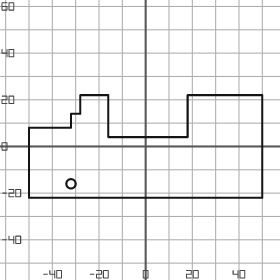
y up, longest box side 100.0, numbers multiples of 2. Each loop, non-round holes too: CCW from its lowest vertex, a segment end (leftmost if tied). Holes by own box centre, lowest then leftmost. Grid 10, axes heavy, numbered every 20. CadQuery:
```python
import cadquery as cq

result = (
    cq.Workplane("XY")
    .moveTo(-50.0, -22.0)
    .lineTo(50.0, -22.0)
    .lineTo(50.0, 22.0)
    .lineTo(18.0, 22.0)
    .lineTo(18.0, 4.0)
    .lineTo(-16.0, 4.0)
    .lineTo(-16.0, 22.0)
    .lineTo(-28.0, 22.0)
    .lineTo(-28.0, 14.0)
    .lineTo(-32.0, 14.0)
    .lineTo(-32.0, 8.0)
    .lineTo(-50.0, 8.0)
    .close()
    .moveTo(-32.0, -16.0)
    .circle(2.0)
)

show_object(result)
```